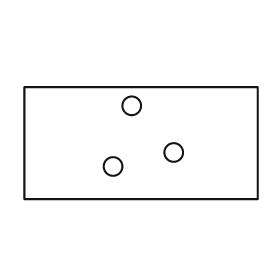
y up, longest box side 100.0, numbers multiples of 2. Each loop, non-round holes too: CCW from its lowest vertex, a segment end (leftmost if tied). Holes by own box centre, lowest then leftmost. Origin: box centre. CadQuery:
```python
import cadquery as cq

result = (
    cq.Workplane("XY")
    .moveTo(-50.0, -24.0)
    .lineTo(50.0, -24.0)
    .lineTo(50.0, 24.0)
    .lineTo(-50.0, 24.0)
    .close()
    .moveTo(-12.0, -10.0)
    .circle(4.0)
    .moveTo(14.0, -4.0)
    .circle(4.0)
    .moveTo(-4.0, 16.0)
    .circle(4.0)
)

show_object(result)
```